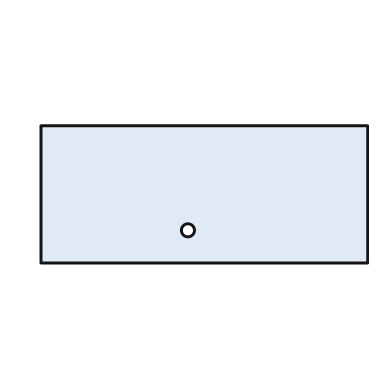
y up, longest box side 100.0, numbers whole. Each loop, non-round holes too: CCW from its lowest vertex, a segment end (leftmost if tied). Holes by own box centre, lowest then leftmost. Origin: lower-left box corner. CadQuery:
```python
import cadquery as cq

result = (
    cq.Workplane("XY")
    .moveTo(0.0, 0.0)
    .lineTo(100.0, 0.0)
    .lineTo(100.0, 42.0)
    .lineTo(0.0, 42.0)
    .close()
    .moveTo(45.0, 10.0)
    .circle(2.0)
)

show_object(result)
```